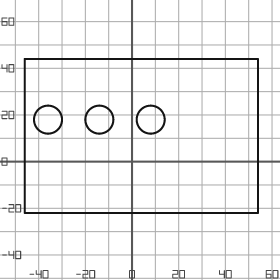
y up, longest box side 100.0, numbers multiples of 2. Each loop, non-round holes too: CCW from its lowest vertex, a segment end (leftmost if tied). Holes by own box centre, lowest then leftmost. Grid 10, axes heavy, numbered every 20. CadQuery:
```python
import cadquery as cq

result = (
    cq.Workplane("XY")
    .moveTo(-46.0, -22.0)
    .lineTo(54.0, -22.0)
    .lineTo(54.0, 44.0)
    .lineTo(-46.0, 44.0)
    .close()
    .moveTo(-36.0, 18.0)
    .circle(6.0)
    .moveTo(-14.0, 18.0)
    .circle(6.0)
    .moveTo(8.0, 18.0)
    .circle(6.0)
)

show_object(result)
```